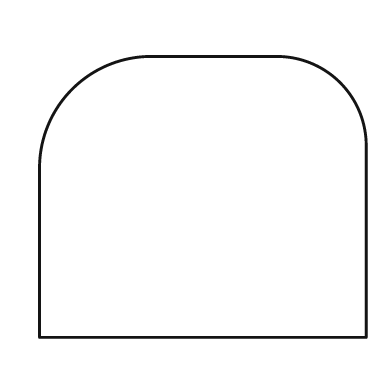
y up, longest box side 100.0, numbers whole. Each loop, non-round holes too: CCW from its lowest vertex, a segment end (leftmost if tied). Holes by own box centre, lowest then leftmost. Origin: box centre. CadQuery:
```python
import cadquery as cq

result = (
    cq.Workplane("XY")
    .moveTo(-50.0, -43.0)
    .lineTo(50.0, -43.0)
    .lineTo(50.0, 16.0)
    .threePointArc((42.0, 35.0), (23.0, 43.0))
    .lineTo(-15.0, 43.0)
    .threePointArc((-40.0, 33.0), (-50.0, 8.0))
    .close()
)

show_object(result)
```